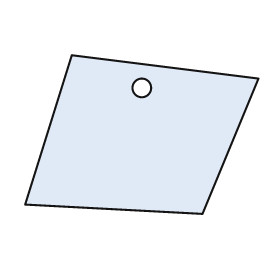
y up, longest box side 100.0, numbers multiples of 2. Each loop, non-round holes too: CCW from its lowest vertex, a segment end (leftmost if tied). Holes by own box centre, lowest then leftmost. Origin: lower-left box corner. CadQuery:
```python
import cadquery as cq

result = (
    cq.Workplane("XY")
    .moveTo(76.0, 0.0)
    .lineTo(100.0, 58.0)
    .lineTo(20.0, 68.0)
    .lineTo(0.0, 4.0)
    .close()
    .moveTo(50.0, 54.0)
    .circle(4.0)
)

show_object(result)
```